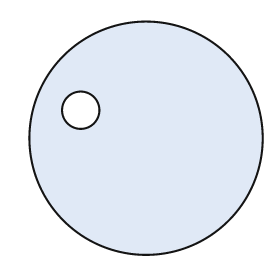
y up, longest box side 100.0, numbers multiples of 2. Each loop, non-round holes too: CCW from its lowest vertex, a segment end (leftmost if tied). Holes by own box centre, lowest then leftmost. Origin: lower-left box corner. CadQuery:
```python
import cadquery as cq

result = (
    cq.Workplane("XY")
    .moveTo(50.0, 50.0)
    .circle(50.0)
    .moveTo(22.0, 62.0)
    .circle(8.0)
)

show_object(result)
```